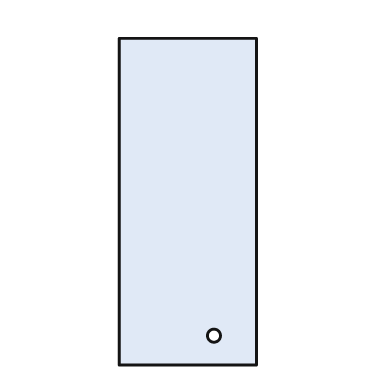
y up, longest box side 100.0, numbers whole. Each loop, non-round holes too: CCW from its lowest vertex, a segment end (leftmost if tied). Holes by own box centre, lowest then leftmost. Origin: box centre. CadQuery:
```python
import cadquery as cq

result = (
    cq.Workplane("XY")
    .moveTo(-21.0, -50.0)
    .lineTo(21.0, -50.0)
    .lineTo(21.0, 50.0)
    .lineTo(-21.0, 50.0)
    .close()
    .moveTo(8.0, -41.0)
    .circle(2.0)
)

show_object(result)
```